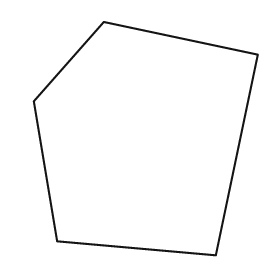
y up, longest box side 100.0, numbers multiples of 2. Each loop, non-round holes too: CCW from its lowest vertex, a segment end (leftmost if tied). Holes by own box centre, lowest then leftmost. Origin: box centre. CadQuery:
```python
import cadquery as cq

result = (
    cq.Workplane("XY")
    .moveTo(30.0, -50.0)
    .lineTo(48.0, 36.0)
    .lineTo(-18.0, 50.0)
    .lineTo(-48.0, 16.0)
    .lineTo(-38.0, -44.0)
    .close()
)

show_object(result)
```